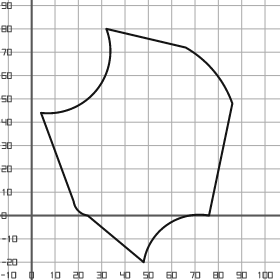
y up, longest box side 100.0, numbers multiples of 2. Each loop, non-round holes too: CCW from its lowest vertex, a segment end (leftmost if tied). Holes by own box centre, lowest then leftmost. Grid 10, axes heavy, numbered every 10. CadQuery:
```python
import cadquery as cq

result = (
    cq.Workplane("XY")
    .moveTo(48.0, -20.0)
    .threePointArc((58.0, -4.0), (76.0, 0.0))
    .lineTo(86.0, 48.0)
    .threePointArc((78.0, 62.0), (66.0, 72.0))
    .lineTo(32.0, 80.0)
    .threePointArc((28.0, 54.0), (4.0, 44.0))
    .lineTo(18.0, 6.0)
    .threePointArc((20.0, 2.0), (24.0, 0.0))
    .close()
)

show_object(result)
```